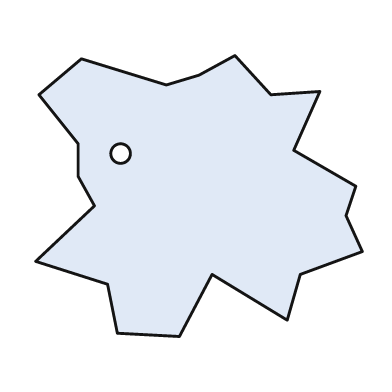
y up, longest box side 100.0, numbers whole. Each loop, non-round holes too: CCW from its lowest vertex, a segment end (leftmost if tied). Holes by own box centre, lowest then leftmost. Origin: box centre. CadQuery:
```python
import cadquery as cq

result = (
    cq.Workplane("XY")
    .moveTo(-6.0, -43.0)
    .lineTo(4.0, -24.0)
    .lineTo(27.0, -38.0)
    .lineTo(31.0, -24.0)
    .lineTo(50.0, -17.0)
    .lineTo(45.0, -6.0)
    .lineTo(48.0, 3.0)
    .lineTo(29.0, 14.0)
    .lineTo(37.0, 32.0)
    .lineTo(22.0, 31.0)
    .lineTo(11.0, 43.0)
    .lineTo(0.0, 37.0)
    .lineTo(-10.0, 34.0)
    .lineTo(-36.0, 42.0)
    .lineTo(-49.0, 31.0)
    .lineTo(-37.0, 16.0)
    .lineTo(-37.0, 6.0)
    .lineTo(-32.0, -3.0)
    .lineTo(-50.0, -20.0)
    .lineTo(-28.0, -27.0)
    .lineTo(-25.0, -42.0)
    .close()
    .moveTo(-24.0, 13.0)
    .circle(3.0)
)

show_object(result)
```